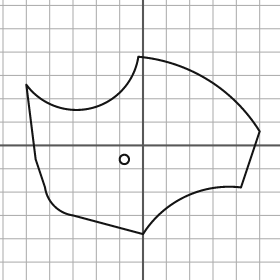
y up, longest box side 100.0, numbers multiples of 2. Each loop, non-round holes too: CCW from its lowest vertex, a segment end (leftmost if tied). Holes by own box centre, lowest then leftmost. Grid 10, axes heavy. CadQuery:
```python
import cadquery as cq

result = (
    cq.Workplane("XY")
    .moveTo(0.0, -38.0)
    .threePointArc((18.0, -22.0), (42.0, -18.0))
    .lineTo(50.0, 6.0)
    .threePointArc((28.0, 28.0), (-2.0, 38.0))
    .threePointArc((-22.0, 16.0), (-50.0, 26.0))
    .lineTo(-46.0, -6.0)
    .lineTo(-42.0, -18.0)
    .threePointArc((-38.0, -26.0), (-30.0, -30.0))
    .close()
    .moveTo(-8.0, -6.0)
    .circle(2.0)
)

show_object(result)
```